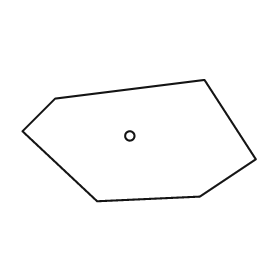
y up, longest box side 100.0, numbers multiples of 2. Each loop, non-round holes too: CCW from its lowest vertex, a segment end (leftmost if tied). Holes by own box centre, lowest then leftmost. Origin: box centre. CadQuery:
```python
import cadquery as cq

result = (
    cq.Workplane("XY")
    .moveTo(-18.0, -26.0)
    .lineTo(26.0, -24.0)
    .lineTo(50.0, -8.0)
    .lineTo(28.0, 26.0)
    .lineTo(-36.0, 18.0)
    .lineTo(-50.0, 4.0)
    .close()
    .moveTo(-4.0, 2.0)
    .circle(2.0)
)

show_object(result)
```